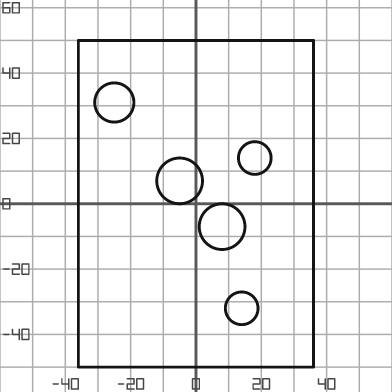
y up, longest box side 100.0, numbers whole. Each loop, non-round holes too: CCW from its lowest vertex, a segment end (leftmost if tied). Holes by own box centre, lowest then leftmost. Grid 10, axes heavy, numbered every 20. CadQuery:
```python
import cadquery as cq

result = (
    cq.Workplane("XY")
    .moveTo(-36.0, -50.0)
    .lineTo(36.0, -50.0)
    .lineTo(36.0, 50.0)
    .lineTo(-36.0, 50.0)
    .close()
    .moveTo(14.0, -32.0)
    .circle(5.0)
    .moveTo(8.0, -7.0)
    .circle(7.0)
    .moveTo(-5.0, 7.0)
    .circle(7.0)
    .moveTo(18.0, 14.0)
    .circle(5.0)
    .moveTo(-25.0, 31.0)
    .circle(6.0)
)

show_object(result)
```